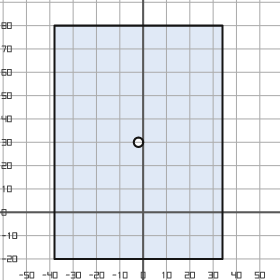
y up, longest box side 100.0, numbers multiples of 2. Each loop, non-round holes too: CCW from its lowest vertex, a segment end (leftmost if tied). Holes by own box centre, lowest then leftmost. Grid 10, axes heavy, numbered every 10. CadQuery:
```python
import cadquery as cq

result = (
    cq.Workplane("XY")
    .moveTo(-38.0, -20.0)
    .lineTo(34.0, -20.0)
    .lineTo(34.0, 80.0)
    .lineTo(-38.0, 80.0)
    .close()
    .moveTo(-2.0, 30.0)
    .circle(2.0)
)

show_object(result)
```